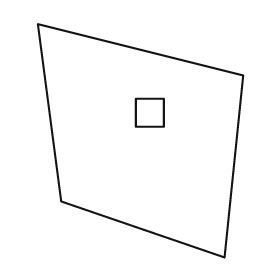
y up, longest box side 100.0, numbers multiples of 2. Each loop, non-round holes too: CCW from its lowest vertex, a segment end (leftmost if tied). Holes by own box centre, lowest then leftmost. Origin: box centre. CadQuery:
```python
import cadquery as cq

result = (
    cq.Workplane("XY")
    .moveTo(36.0, -50.0)
    .lineTo(44.0, 28.0)
    .lineTo(-44.0, 50.0)
    .lineTo(-34.0, -26.0)
    .close()
    .moveTo(-2.0, 6.0)
    .lineTo(10.0, 6.0)
    .lineTo(10.0, 18.0)
    .lineTo(-2.0, 18.0)
    .close()
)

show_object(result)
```